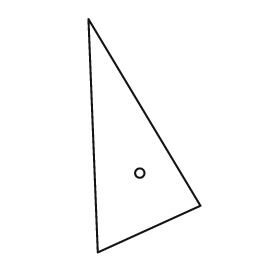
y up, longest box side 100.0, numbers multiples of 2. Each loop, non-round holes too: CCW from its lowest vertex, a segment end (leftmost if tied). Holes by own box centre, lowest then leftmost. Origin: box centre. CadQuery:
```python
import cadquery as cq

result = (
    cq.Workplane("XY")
    .moveTo(-20.0, -50.0)
    .lineTo(24.0, -30.0)
    .lineTo(-24.0, 50.0)
    .close()
    .moveTo(-2.0, -16.0)
    .circle(2.0)
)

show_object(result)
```